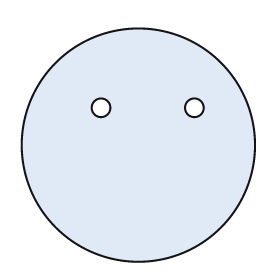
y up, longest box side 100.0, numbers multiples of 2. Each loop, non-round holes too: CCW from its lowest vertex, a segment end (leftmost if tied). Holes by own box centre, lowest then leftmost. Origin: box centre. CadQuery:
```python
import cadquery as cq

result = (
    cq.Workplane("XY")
    .moveTo(0.0, 0.0)
    .circle(50.0)
    .moveTo(-16.0, 16.0)
    .circle(4.0)
    .moveTo(24.0, 16.0)
    .circle(4.0)
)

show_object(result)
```